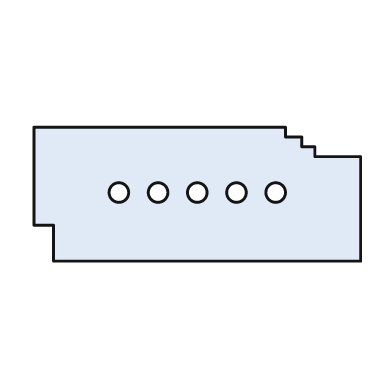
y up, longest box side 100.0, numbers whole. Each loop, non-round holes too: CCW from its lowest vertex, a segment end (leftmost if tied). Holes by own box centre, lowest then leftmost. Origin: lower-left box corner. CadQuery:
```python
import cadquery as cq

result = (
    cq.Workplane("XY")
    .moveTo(6.0, 0.0)
    .lineTo(100.0, 0.0)
    .lineTo(100.0, 32.0)
    .lineTo(86.0, 32.0)
    .lineTo(86.0, 35.0)
    .lineTo(82.0, 35.0)
    .lineTo(82.0, 38.0)
    .lineTo(77.0, 38.0)
    .lineTo(77.0, 41.0)
    .lineTo(0.0, 41.0)
    .lineTo(0.0, 11.0)
    .lineTo(6.0, 11.0)
    .close()
    .moveTo(26.0, 21.0)
    .circle(3.0)
    .moveTo(38.0, 21.0)
    .circle(3.0)
    .moveTo(50.0, 21.0)
    .circle(3.0)
    .moveTo(62.0, 21.0)
    .circle(3.0)
    .moveTo(74.0, 21.0)
    .circle(3.0)
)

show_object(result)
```